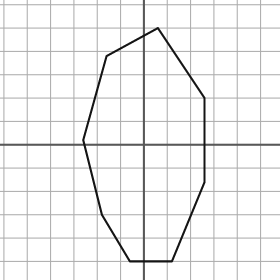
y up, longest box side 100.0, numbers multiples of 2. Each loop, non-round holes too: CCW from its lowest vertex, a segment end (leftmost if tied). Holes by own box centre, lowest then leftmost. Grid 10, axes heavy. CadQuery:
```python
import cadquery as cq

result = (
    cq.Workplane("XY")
    .moveTo(-6.0, -50.0)
    .lineTo(12.0, -50.0)
    .lineTo(26.0, -16.0)
    .lineTo(26.0, 20.0)
    .lineTo(6.0, 50.0)
    .lineTo(-16.0, 38.0)
    .lineTo(-26.0, 2.0)
    .lineTo(-18.0, -30.0)
    .close()
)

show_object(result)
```